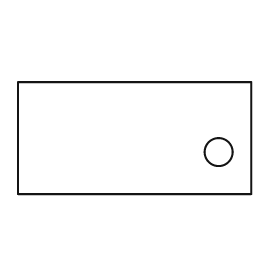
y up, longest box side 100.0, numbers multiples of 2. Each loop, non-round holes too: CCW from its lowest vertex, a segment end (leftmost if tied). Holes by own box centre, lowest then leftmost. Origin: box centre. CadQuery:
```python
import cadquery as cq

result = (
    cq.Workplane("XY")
    .moveTo(-50.0, -24.0)
    .lineTo(50.0, -24.0)
    .lineTo(50.0, 24.0)
    .lineTo(-50.0, 24.0)
    .close()
    .moveTo(36.0, -6.0)
    .circle(6.0)
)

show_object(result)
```